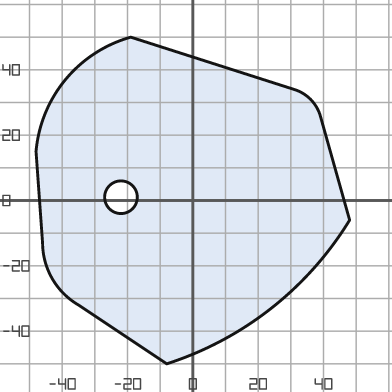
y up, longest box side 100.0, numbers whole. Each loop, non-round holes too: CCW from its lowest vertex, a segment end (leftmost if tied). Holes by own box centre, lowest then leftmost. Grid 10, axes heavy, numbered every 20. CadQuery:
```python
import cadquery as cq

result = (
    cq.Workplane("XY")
    .moveTo(-8.0, -50.0)
    .threePointArc((24.0, -33.0), (48.0, -6.0))
    .lineTo(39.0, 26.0)
    .threePointArc((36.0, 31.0), (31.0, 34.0))
    .lineTo(-19.0, 50.0)
    .threePointArc((-39.0, 37.0), (-48.0, 15.0))
    .lineTo(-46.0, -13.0)
    .threePointArc((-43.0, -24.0), (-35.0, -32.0))
    .close()
    .moveTo(-22.0, 1.0)
    .circle(5.0)
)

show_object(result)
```